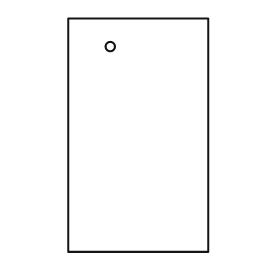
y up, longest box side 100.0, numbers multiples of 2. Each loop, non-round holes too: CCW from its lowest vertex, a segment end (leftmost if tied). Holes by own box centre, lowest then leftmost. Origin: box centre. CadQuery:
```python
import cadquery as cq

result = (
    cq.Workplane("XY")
    .moveTo(-30.0, -50.0)
    .lineTo(30.0, -50.0)
    .lineTo(30.0, 50.0)
    .lineTo(-30.0, 50.0)
    .close()
    .moveTo(-12.0, 38.0)
    .circle(2.0)
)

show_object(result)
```